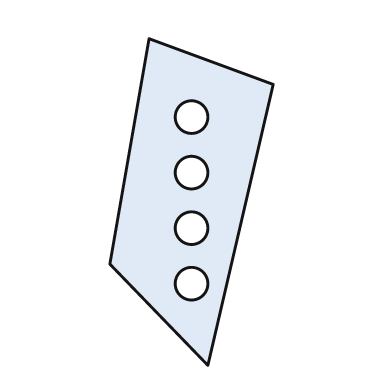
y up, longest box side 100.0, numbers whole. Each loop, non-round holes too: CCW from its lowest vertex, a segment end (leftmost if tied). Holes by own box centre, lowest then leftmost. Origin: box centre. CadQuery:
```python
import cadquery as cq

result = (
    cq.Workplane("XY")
    .moveTo(5.0, -50.0)
    .lineTo(25.0, 36.0)
    .lineTo(-13.0, 50.0)
    .lineTo(-25.0, -19.0)
    .close()
    .moveTo(0.0, -25.0)
    .circle(5.0)
    .moveTo(0.0, -8.0)
    .circle(5.0)
    .moveTo(0.0, 9.0)
    .circle(5.0)
    .moveTo(0.0, 26.0)
    .circle(5.0)
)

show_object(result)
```